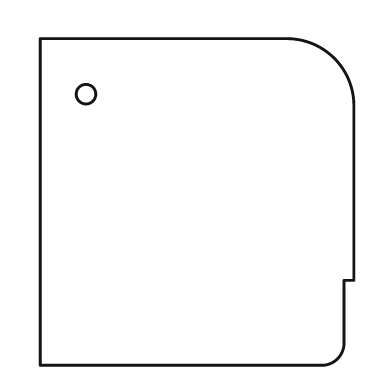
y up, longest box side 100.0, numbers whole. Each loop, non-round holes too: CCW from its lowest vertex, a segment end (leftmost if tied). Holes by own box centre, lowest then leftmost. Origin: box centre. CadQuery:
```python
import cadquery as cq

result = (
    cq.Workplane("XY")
    .moveTo(-48.0, -50.0)
    .lineTo(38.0, -50.0)
    .threePointArc((43.0, -48.0), (45.0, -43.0))
    .lineTo(45.0, -24.0)
    .lineTo(48.0, -24.0)
    .lineTo(48.0, 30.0)
    .threePointArc((42.0, 44.0), (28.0, 50.0))
    .lineTo(-48.0, 50.0)
    .close()
    .moveTo(-34.0, 33.0)
    .circle(3.0)
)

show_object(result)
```